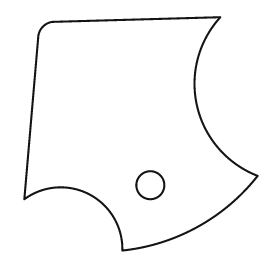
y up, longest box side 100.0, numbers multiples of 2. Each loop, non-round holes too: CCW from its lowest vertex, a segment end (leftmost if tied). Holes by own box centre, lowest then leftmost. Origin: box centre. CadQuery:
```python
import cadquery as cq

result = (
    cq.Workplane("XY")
    .moveTo(-8.0, -50.0)
    .threePointArc((24.0, -40.0), (50.0, -18.0))
    .threePointArc((24.0, 12.0), (34.0, 50.0))
    .lineTo(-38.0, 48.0)
    .threePointArc((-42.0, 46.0), (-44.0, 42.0))
    .lineTo(-50.0, -28.0)
    .threePointArc((-22.0, -26.0), (-8.0, -50.0))
    .close()
    .moveTo(4.0, -22.0)
    .circle(6.0)
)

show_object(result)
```